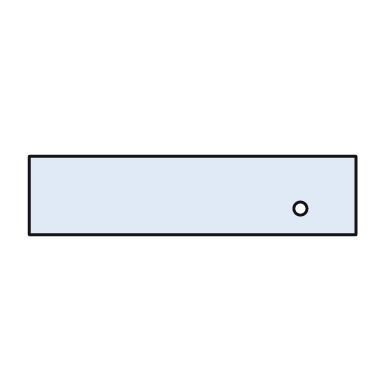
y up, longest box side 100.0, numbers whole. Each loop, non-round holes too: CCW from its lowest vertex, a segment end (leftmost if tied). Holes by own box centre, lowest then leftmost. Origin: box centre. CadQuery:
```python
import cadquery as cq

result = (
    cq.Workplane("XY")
    .moveTo(-50.0, -12.0)
    .lineTo(50.0, -12.0)
    .lineTo(50.0, 12.0)
    .lineTo(-50.0, 12.0)
    .close()
    .moveTo(33.0, -4.0)
    .circle(2.0)
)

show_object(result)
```